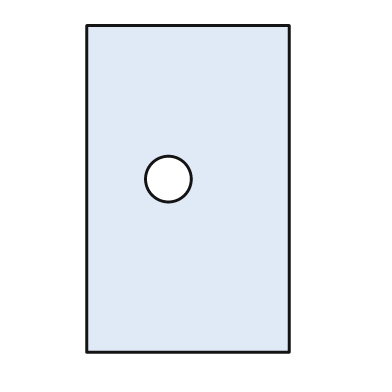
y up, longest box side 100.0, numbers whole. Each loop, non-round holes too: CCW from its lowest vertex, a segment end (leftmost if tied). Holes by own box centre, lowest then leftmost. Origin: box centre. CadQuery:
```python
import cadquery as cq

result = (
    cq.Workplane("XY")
    .moveTo(-31.0, -50.0)
    .lineTo(31.0, -50.0)
    .lineTo(31.0, 50.0)
    .lineTo(-31.0, 50.0)
    .close()
    .moveTo(-6.0, 3.0)
    .circle(7.0)
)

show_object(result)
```